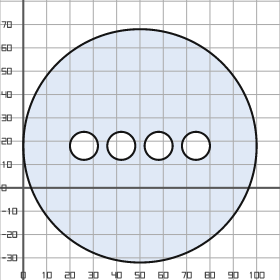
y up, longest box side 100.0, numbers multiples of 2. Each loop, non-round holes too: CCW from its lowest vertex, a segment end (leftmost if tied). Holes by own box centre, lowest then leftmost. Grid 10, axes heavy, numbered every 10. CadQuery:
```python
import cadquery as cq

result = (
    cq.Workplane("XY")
    .moveTo(50.0, 18.0)
    .circle(50.0)
    .moveTo(26.0, 18.0)
    .circle(6.0)
    .moveTo(42.0, 18.0)
    .circle(6.0)
    .moveTo(58.0, 18.0)
    .circle(6.0)
    .moveTo(74.0, 18.0)
    .circle(6.0)
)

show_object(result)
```